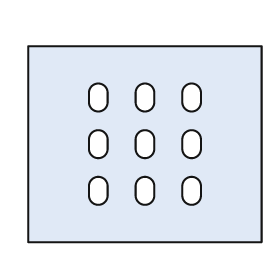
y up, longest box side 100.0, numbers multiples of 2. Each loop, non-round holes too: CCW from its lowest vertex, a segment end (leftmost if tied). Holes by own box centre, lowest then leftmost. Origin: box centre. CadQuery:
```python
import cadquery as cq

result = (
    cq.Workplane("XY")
    .moveTo(-50.0, -42.0)
    .lineTo(50.0, -42.0)
    .lineTo(50.0, 42.0)
    .lineTo(-50.0, 42.0)
    .close()
    .moveTo(-24.0, -22.0)
    .threePointArc((-20.0, -26.0), (-16.0, -22.0))
    .lineTo(-16.0, -18.0)
    .threePointArc((-20.0, -14.0), (-24.0, -18.0))
    .close()
    .moveTo(-4.0, -22.0)
    .threePointArc((0.0, -26.0), (4.0, -22.0))
    .lineTo(4.0, -18.0)
    .threePointArc((0.0, -14.0), (-4.0, -18.0))
    .close()
    .moveTo(16.0, -22.0)
    .threePointArc((20.0, -26.0), (24.0, -22.0))
    .lineTo(24.0, -18.0)
    .threePointArc((20.0, -14.0), (16.0, -18.0))
    .close()
    .moveTo(-24.0, -2.0)
    .threePointArc((-20.0, -6.0), (-16.0, -2.0))
    .lineTo(-16.0, 2.0)
    .threePointArc((-20.0, 6.0), (-24.0, 2.0))
    .close()
    .moveTo(-4.0, -2.0)
    .threePointArc((0.0, -6.0), (4.0, -2.0))
    .lineTo(4.0, 2.0)
    .threePointArc((0.0, 6.0), (-4.0, 2.0))
    .close()
    .moveTo(16.0, -2.0)
    .threePointArc((20.0, -6.0), (24.0, -2.0))
    .lineTo(24.0, 2.0)
    .threePointArc((20.0, 6.0), (16.0, 2.0))
    .close()
    .moveTo(-24.0, 18.0)
    .threePointArc((-20.0, 14.0), (-16.0, 18.0))
    .lineTo(-16.0, 22.0)
    .threePointArc((-20.0, 26.0), (-24.0, 22.0))
    .close()
    .moveTo(-4.0, 18.0)
    .threePointArc((0.0, 14.0), (4.0, 18.0))
    .lineTo(4.0, 22.0)
    .threePointArc((0.0, 26.0), (-4.0, 22.0))
    .close()
    .moveTo(16.0, 18.0)
    .threePointArc((20.0, 14.0), (24.0, 18.0))
    .lineTo(24.0, 22.0)
    .threePointArc((20.0, 26.0), (16.0, 22.0))
    .close()
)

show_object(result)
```